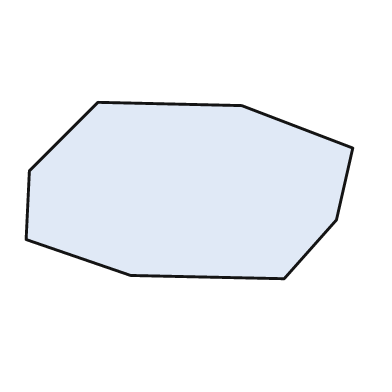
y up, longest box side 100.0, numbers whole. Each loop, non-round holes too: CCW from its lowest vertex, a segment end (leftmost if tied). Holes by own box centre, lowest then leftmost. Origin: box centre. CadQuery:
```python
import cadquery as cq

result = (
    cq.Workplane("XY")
    .moveTo(29.0, -27.0)
    .lineTo(45.0, -9.0)
    .lineTo(50.0, 13.0)
    .lineTo(16.0, 26.0)
    .lineTo(-28.0, 27.0)
    .lineTo(-49.0, 6.0)
    .lineTo(-50.0, -15.0)
    .lineTo(-18.0, -26.0)
    .close()
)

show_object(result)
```